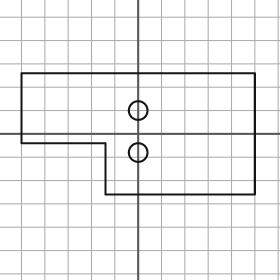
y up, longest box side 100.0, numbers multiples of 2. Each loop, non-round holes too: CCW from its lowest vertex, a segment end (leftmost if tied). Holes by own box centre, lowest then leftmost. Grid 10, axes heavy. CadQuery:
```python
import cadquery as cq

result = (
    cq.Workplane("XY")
    .moveTo(-14.0, -26.0)
    .lineTo(50.0, -26.0)
    .lineTo(50.0, 26.0)
    .lineTo(-50.0, 26.0)
    .lineTo(-50.0, -4.0)
    .lineTo(-14.0, -4.0)
    .close()
    .moveTo(0.0, -8.0)
    .circle(4.0)
    .moveTo(0.0, 10.0)
    .circle(4.0)
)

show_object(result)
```